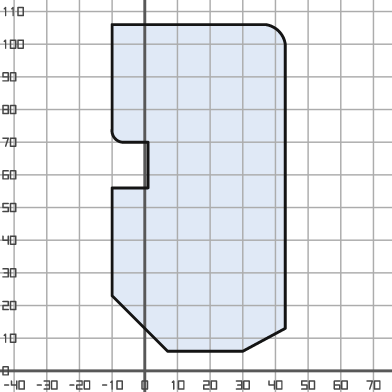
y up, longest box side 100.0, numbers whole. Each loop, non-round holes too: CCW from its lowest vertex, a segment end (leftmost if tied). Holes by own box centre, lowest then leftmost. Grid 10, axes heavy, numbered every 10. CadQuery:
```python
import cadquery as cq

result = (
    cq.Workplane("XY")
    .moveTo(7.0, 6.0)
    .lineTo(30.0, 6.0)
    .lineTo(43.0, 13.0)
    .lineTo(43.0, 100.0)
    .threePointArc((41.0, 104.0), (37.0, 106.0))
    .lineTo(-10.0, 106.0)
    .lineTo(-10.0, 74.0)
    .threePointArc((-9.0, 71.0), (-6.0, 70.0))
    .lineTo(1.0, 70.0)
    .lineTo(1.0, 56.0)
    .lineTo(-10.0, 56.0)
    .lineTo(-10.0, 23.0)
    .close()
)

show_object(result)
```